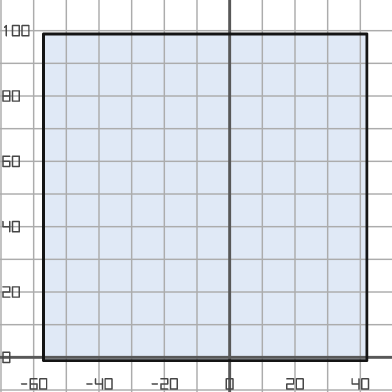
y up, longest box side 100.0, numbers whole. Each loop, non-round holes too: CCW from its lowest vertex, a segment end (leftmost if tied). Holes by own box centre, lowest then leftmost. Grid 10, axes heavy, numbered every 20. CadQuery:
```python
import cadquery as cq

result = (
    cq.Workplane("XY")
    .moveTo(-57.0, -1.0)
    .lineTo(42.0, -1.0)
    .lineTo(42.0, 99.0)
    .lineTo(-57.0, 99.0)
    .close()
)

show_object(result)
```